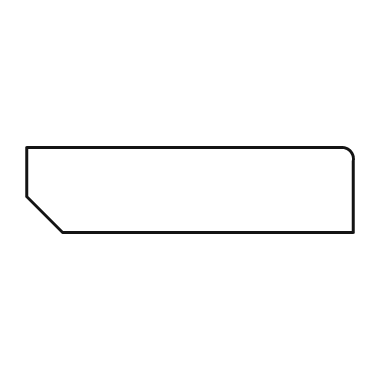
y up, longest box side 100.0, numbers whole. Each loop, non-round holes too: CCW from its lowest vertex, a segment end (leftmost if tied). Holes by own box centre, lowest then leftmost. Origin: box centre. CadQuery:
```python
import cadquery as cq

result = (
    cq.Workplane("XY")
    .moveTo(-39.0, -13.0)
    .lineTo(50.0, -13.0)
    .lineTo(50.0, 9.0)
    .threePointArc((49.0, 12.0), (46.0, 13.0))
    .lineTo(-50.0, 13.0)
    .lineTo(-50.0, -2.0)
    .close()
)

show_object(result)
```